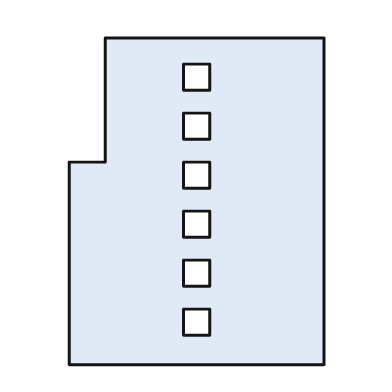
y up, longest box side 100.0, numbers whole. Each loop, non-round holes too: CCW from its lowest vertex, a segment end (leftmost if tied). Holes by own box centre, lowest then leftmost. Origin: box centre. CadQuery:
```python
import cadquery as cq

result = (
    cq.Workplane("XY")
    .moveTo(-39.0, -50.0)
    .lineTo(39.0, -50.0)
    .lineTo(39.0, 50.0)
    .lineTo(-28.0, 50.0)
    .lineTo(-28.0, 12.0)
    .lineTo(-39.0, 12.0)
    .close()
    .moveTo(-4.0, -41.0)
    .lineTo(4.0, -41.0)
    .lineTo(4.0, -33.0)
    .lineTo(-4.0, -33.0)
    .close()
    .moveTo(-4.0, -26.0)
    .lineTo(4.0, -26.0)
    .lineTo(4.0, -18.0)
    .lineTo(-4.0, -18.0)
    .close()
    .moveTo(-4.0, -11.0)
    .lineTo(4.0, -11.0)
    .lineTo(4.0, -3.0)
    .lineTo(-4.0, -3.0)
    .close()
    .moveTo(-4.0, 4.0)
    .lineTo(4.0, 4.0)
    .lineTo(4.0, 12.0)
    .lineTo(-4.0, 12.0)
    .close()
    .moveTo(-4.0, 19.0)
    .lineTo(4.0, 19.0)
    .lineTo(4.0, 27.0)
    .lineTo(-4.0, 27.0)
    .close()
    .moveTo(-4.0, 34.0)
    .lineTo(4.0, 34.0)
    .lineTo(4.0, 42.0)
    .lineTo(-4.0, 42.0)
    .close()
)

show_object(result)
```